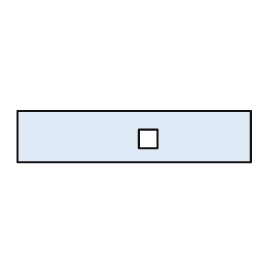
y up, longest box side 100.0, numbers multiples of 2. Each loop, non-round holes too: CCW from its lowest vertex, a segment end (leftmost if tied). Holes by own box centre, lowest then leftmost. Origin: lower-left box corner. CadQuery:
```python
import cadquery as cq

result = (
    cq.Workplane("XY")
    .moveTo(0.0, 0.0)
    .lineTo(100.0, 0.0)
    .lineTo(100.0, 22.0)
    .lineTo(0.0, 22.0)
    .close()
    .moveTo(52.0, 6.0)
    .lineTo(60.0, 6.0)
    .lineTo(60.0, 14.0)
    .lineTo(52.0, 14.0)
    .close()
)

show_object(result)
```